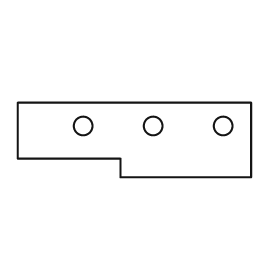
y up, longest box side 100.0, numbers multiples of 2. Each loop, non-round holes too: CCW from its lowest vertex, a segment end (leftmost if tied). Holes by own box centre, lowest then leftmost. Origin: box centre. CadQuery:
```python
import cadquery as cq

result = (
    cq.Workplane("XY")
    .moveTo(-6.0, -16.0)
    .lineTo(50.0, -16.0)
    .lineTo(50.0, 16.0)
    .lineTo(-50.0, 16.0)
    .lineTo(-50.0, -8.0)
    .lineTo(-6.0, -8.0)
    .close()
    .moveTo(-22.0, 6.0)
    .circle(4.0)
    .moveTo(8.0, 6.0)
    .circle(4.0)
    .moveTo(38.0, 6.0)
    .circle(4.0)
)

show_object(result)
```